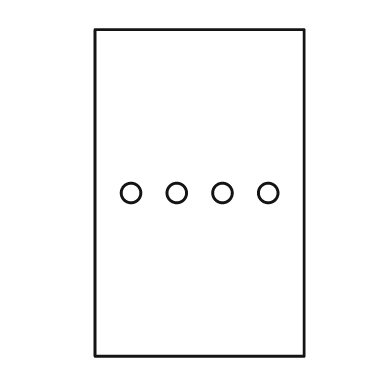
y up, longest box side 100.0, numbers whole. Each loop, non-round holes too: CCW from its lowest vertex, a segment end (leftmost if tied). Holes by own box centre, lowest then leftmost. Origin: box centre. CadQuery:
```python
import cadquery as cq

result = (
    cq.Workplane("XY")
    .moveTo(-32.0, -50.0)
    .lineTo(32.0, -50.0)
    .lineTo(32.0, 50.0)
    .lineTo(-32.0, 50.0)
    .close()
    .moveTo(-21.0, 0.0)
    .circle(3.0)
    .moveTo(-7.0, 0.0)
    .circle(3.0)
    .moveTo(7.0, 0.0)
    .circle(3.0)
    .moveTo(21.0, 0.0)
    .circle(3.0)
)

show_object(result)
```